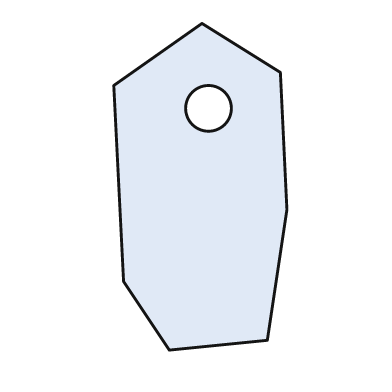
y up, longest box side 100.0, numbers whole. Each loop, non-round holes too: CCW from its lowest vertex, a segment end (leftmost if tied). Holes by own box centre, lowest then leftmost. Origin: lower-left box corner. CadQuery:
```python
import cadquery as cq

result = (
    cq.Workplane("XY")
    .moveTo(17.0, 0.0)
    .lineTo(47.0, 3.0)
    .lineTo(53.0, 43.0)
    .lineTo(51.0, 85.0)
    .lineTo(27.0, 100.0)
    .lineTo(0.0, 81.0)
    .lineTo(3.0, 21.0)
    .close()
    .moveTo(29.0, 74.0)
    .circle(7.0)
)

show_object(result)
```